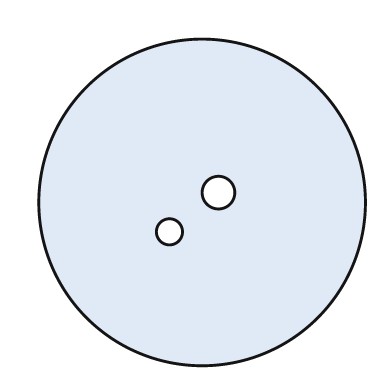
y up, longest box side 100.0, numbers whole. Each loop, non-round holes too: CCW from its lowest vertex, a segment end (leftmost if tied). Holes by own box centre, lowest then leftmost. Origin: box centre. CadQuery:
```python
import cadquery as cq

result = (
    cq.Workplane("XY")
    .moveTo(0.0, 0.0)
    .circle(50.0)
    .moveTo(-10.0, -9.0)
    .circle(4.0)
    .moveTo(5.0, 3.0)
    .circle(5.0)
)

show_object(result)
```